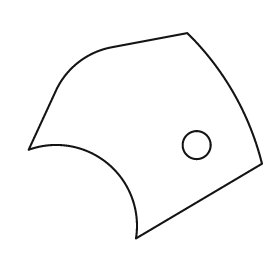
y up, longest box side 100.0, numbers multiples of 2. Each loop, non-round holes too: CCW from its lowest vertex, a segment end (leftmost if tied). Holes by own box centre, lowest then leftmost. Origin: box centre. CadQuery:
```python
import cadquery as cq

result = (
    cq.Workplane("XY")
    .moveTo(-4.0, -44.0)
    .lineTo(50.0, -12.0)
    .threePointArc((38.0, 18.0), (18.0, 44.0))
    .lineTo(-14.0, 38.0)
    .threePointArc((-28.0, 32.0), (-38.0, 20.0))
    .lineTo(-50.0, -6.0)
    .threePointArc((-16.0, -12.0), (-4.0, -44.0))
    .close()
    .moveTo(22.0, -4.0)
    .circle(6.0)
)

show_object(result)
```